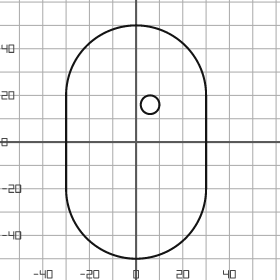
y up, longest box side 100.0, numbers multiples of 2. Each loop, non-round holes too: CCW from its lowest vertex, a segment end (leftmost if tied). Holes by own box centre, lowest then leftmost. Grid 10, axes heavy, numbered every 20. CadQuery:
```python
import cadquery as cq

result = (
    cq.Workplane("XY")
    .moveTo(-30.0, -20.0)
    .threePointArc((0.0, -50.0), (30.0, -20.0))
    .lineTo(30.0, 20.0)
    .threePointArc((0.0, 50.0), (-30.0, 20.0))
    .close()
    .moveTo(6.0, 16.0)
    .circle(4.0)
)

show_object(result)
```